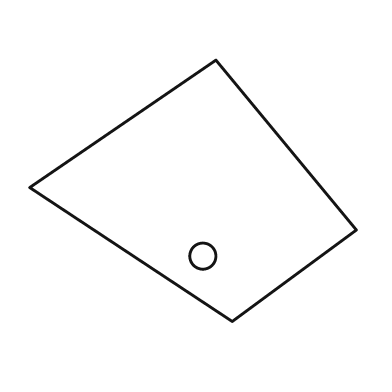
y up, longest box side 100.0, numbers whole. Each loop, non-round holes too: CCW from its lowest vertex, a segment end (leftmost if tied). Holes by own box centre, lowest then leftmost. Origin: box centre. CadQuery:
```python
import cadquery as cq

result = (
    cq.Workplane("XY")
    .moveTo(12.0, -40.0)
    .lineTo(50.0, -12.0)
    .lineTo(7.0, 40.0)
    .lineTo(-50.0, 1.0)
    .close()
    .moveTo(3.0, -20.0)
    .circle(4.0)
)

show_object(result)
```